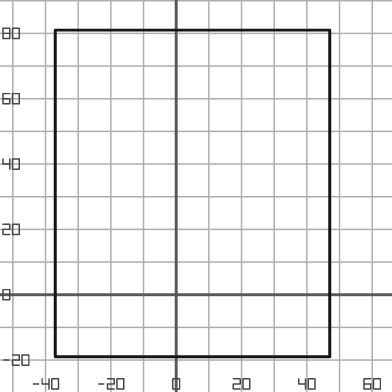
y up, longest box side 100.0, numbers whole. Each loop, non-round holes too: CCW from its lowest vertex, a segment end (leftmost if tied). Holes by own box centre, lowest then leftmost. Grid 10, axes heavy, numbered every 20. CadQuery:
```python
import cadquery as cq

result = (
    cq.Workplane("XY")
    .moveTo(-37.0, -19.0)
    .lineTo(47.0, -19.0)
    .lineTo(47.0, 81.0)
    .lineTo(-37.0, 81.0)
    .close()
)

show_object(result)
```